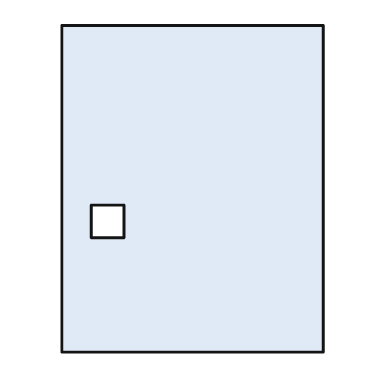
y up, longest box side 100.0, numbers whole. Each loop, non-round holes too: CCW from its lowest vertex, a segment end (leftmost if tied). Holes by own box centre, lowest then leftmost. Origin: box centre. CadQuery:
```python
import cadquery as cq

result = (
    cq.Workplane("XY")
    .moveTo(-40.0, -50.0)
    .lineTo(40.0, -50.0)
    .lineTo(40.0, 50.0)
    .lineTo(-40.0, 50.0)
    .close()
    .moveTo(-31.0, -15.0)
    .lineTo(-21.0, -15.0)
    .lineTo(-21.0, -5.0)
    .lineTo(-31.0, -5.0)
    .close()
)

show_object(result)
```